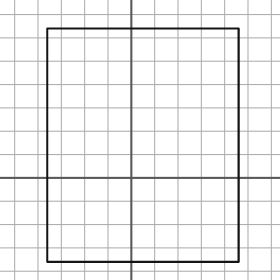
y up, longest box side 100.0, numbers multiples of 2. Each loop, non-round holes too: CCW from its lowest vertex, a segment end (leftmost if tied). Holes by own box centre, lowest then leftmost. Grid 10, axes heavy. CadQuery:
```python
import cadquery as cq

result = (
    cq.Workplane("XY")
    .moveTo(-36.0, -36.0)
    .lineTo(46.0, -36.0)
    .lineTo(46.0, 64.0)
    .lineTo(-36.0, 64.0)
    .close()
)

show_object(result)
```